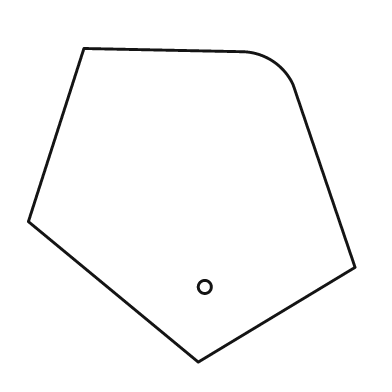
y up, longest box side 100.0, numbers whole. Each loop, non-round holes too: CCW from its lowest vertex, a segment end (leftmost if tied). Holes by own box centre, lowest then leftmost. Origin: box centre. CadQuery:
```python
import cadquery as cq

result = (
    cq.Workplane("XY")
    .moveTo(2.0, -48.0)
    .lineTo(50.0, -19.0)
    .lineTo(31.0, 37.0)
    .threePointArc((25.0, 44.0), (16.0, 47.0))
    .lineTo(-33.0, 48.0)
    .lineTo(-50.0, -5.0)
    .close()
    .moveTo(4.0, -25.0)
    .circle(2.0)
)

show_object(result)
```